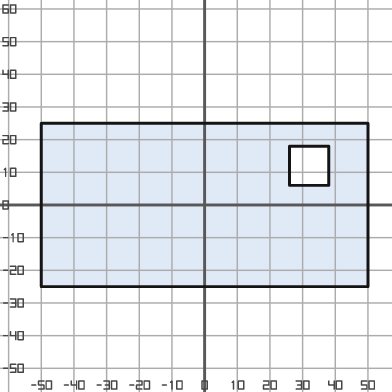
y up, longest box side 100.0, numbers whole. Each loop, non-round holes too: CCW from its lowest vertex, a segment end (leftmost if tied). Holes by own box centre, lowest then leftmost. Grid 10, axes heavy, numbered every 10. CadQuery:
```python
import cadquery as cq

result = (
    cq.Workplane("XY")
    .moveTo(-50.0, -25.0)
    .lineTo(50.0, -25.0)
    .lineTo(50.0, 25.0)
    .lineTo(-50.0, 25.0)
    .close()
    .moveTo(26.0, 6.0)
    .lineTo(38.0, 6.0)
    .lineTo(38.0, 18.0)
    .lineTo(26.0, 18.0)
    .close()
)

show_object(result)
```